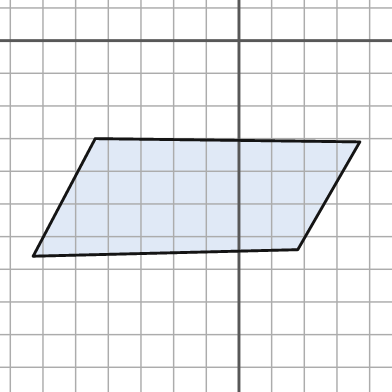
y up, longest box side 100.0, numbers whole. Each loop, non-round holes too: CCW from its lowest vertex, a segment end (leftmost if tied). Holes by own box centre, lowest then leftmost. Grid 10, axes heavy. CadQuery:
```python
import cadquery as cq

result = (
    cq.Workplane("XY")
    .moveTo(-63.0, -66.0)
    .lineTo(18.0, -64.0)
    .lineTo(37.0, -31.0)
    .lineTo(-44.0, -30.0)
    .close()
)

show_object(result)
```